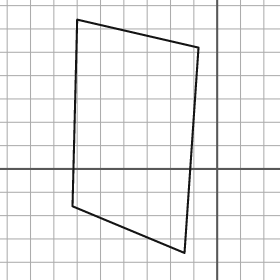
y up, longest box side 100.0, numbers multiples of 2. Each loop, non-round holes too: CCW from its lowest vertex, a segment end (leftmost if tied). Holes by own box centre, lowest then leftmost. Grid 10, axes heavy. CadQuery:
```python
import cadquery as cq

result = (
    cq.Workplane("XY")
    .moveTo(-14.0, -36.0)
    .lineTo(-8.0, 52.0)
    .lineTo(-60.0, 64.0)
    .lineTo(-62.0, -16.0)
    .close()
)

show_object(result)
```